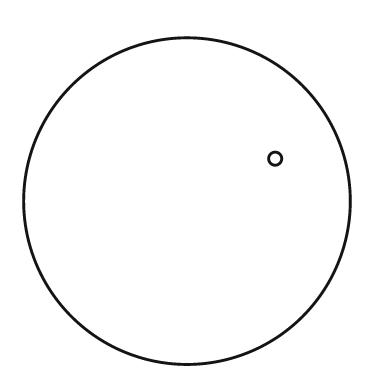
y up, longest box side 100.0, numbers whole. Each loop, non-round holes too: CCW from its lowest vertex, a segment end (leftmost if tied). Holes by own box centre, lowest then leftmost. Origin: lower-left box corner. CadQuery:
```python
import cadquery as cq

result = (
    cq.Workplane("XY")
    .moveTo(50.0, 50.0)
    .circle(50.0)
    .moveTo(77.0, 63.0)
    .circle(2.0)
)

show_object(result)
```